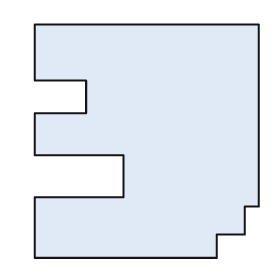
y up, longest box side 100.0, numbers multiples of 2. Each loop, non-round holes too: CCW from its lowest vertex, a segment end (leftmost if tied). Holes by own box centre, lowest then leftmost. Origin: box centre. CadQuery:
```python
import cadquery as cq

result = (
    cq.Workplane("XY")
    .moveTo(-48.0, -50.0)
    .lineTo(30.0, -50.0)
    .lineTo(30.0, -40.0)
    .lineTo(42.0, -40.0)
    .lineTo(42.0, -28.0)
    .lineTo(48.0, -28.0)
    .lineTo(48.0, 50.0)
    .lineTo(-48.0, 50.0)
    .lineTo(-48.0, 26.0)
    .lineTo(-26.0, 26.0)
    .lineTo(-26.0, 12.0)
    .lineTo(-48.0, 12.0)
    .lineTo(-48.0, -6.0)
    .lineTo(-10.0, -6.0)
    .lineTo(-10.0, -24.0)
    .lineTo(-48.0, -24.0)
    .close()
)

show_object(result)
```